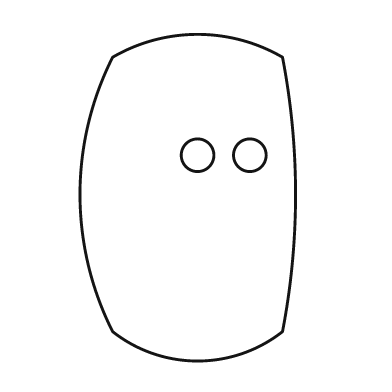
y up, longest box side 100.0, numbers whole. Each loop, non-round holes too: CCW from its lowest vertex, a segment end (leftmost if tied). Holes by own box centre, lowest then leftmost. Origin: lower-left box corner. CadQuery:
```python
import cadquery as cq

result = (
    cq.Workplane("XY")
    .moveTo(10.0, 9.0)
    .threePointArc((36.0, 0.0), (62.0, 9.0))
    .threePointArc((66.0, 51.0), (62.0, 93.0))
    .threePointArc((36.0, 100.0), (10.0, 93.0))
    .threePointArc((0.0, 51.0), (10.0, 9.0))
    .close()
    .moveTo(36.0, 63.0)
    .circle(5.0)
    .moveTo(52.0, 63.0)
    .circle(5.0)
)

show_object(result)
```